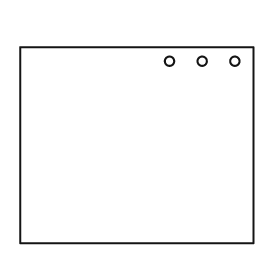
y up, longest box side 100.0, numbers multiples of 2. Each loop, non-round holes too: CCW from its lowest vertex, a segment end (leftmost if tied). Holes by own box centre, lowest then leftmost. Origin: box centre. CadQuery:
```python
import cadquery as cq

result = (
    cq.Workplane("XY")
    .moveTo(-50.0, -42.0)
    .lineTo(50.0, -42.0)
    .lineTo(50.0, 42.0)
    .lineTo(-50.0, 42.0)
    .close()
    .moveTo(14.0, 36.0)
    .circle(2.0)
    .moveTo(28.0, 36.0)
    .circle(2.0)
    .moveTo(42.0, 36.0)
    .circle(2.0)
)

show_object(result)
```